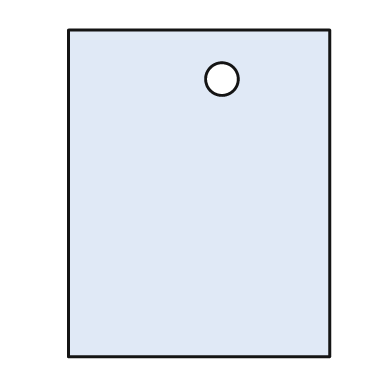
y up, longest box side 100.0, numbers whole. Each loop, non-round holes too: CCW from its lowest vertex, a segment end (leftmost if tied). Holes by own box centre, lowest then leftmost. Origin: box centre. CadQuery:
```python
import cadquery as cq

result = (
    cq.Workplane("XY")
    .moveTo(-40.0, -50.0)
    .lineTo(40.0, -50.0)
    .lineTo(40.0, 50.0)
    .lineTo(-40.0, 50.0)
    .close()
    .moveTo(7.0, 35.0)
    .circle(5.0)
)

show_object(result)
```